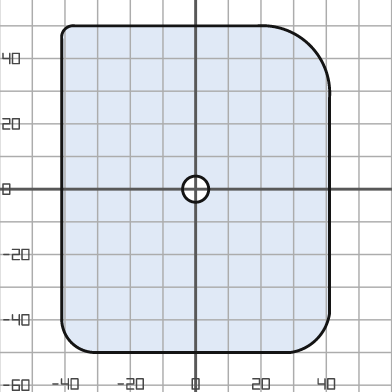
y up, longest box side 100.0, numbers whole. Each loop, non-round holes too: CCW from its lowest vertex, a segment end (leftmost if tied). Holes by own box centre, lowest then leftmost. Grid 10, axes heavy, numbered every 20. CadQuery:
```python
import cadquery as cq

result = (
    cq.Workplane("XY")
    .moveTo(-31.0, -50.0)
    .lineTo(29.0, -50.0)
    .threePointArc((37.0, -46.0), (41.0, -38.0))
    .lineTo(41.0, 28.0)
    .threePointArc((35.0, 44.0), (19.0, 50.0))
    .lineTo(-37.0, 50.0)
    .threePointArc((-40.0, 49.0), (-41.0, 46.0))
    .lineTo(-41.0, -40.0)
    .threePointArc((-38.0, -47.0), (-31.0, -50.0))
    .close()
    .moveTo(0.0, 0.0)
    .circle(4.0)
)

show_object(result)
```